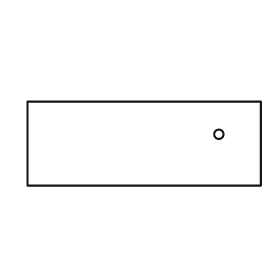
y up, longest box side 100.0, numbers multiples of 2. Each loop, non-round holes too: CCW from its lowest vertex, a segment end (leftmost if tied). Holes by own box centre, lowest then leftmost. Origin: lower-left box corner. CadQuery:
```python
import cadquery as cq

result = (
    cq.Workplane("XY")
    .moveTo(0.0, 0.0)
    .lineTo(100.0, 0.0)
    .lineTo(100.0, 36.0)
    .lineTo(0.0, 36.0)
    .close()
    .moveTo(82.0, 22.0)
    .circle(2.0)
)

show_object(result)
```